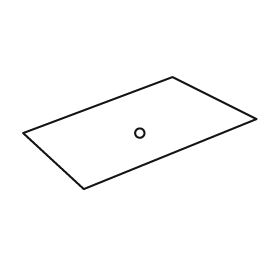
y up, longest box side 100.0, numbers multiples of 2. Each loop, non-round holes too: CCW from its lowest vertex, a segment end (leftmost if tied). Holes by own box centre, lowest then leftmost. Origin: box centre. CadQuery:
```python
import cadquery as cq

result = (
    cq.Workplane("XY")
    .moveTo(-24.0, -24.0)
    .lineTo(50.0, 6.0)
    .lineTo(14.0, 24.0)
    .lineTo(-50.0, 0.0)
    .close()
    .moveTo(0.0, 0.0)
    .circle(2.0)
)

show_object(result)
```